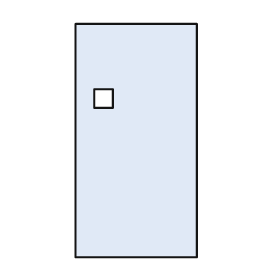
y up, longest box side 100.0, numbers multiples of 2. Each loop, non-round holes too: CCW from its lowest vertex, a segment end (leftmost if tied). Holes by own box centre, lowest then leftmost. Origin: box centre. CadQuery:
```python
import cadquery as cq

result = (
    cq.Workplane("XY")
    .moveTo(-26.0, -50.0)
    .lineTo(26.0, -50.0)
    .lineTo(26.0, 50.0)
    .lineTo(-26.0, 50.0)
    .close()
    .moveTo(-18.0, 14.0)
    .lineTo(-10.0, 14.0)
    .lineTo(-10.0, 22.0)
    .lineTo(-18.0, 22.0)
    .close()
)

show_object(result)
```